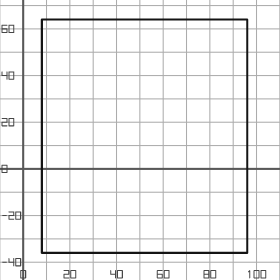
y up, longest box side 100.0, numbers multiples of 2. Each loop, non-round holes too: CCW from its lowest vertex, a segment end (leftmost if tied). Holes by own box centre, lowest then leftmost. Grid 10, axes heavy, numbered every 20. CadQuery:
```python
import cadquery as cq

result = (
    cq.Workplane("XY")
    .moveTo(8.0, -36.0)
    .lineTo(96.0, -36.0)
    .lineTo(96.0, 64.0)
    .lineTo(8.0, 64.0)
    .close()
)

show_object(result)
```